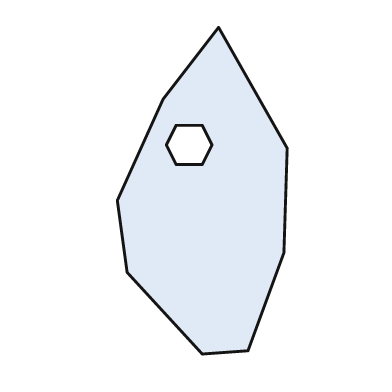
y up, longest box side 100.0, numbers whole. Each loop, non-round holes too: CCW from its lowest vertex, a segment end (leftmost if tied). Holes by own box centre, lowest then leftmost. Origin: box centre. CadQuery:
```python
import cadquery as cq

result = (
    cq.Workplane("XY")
    .moveTo(0.0, -50.0)
    .lineTo(14.0, -49.0)
    .lineTo(25.0, -19.0)
    .lineTo(26.0, 13.0)
    .lineTo(5.0, 50.0)
    .lineTo(-12.0, 28.0)
    .lineTo(-26.0, -3.0)
    .lineTo(-23.0, -25.0)
    .close()
    .moveTo(-8.0, 8.0)
    .lineTo(0.0, 8.0)
    .lineTo(3.0, 14.0)
    .lineTo(0.0, 20.0)
    .lineTo(-8.0, 20.0)
    .lineTo(-11.0, 14.0)
    .close()
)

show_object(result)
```